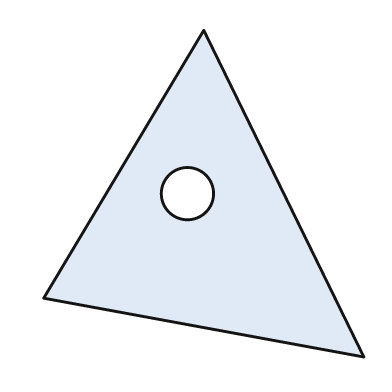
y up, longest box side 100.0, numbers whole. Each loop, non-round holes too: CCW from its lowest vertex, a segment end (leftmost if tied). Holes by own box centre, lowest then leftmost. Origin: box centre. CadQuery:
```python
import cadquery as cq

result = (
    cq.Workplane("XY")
    .moveTo(49.0, -50.0)
    .lineTo(0.0, 50.0)
    .lineTo(-49.0, -32.0)
    .close()
    .moveTo(-5.0, 0.0)
    .circle(8.0)
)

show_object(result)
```